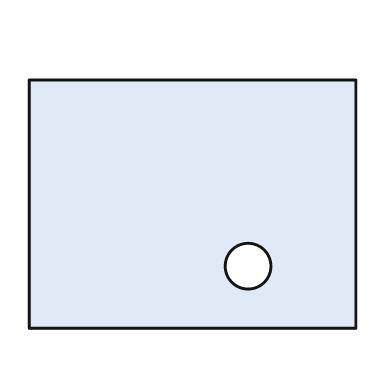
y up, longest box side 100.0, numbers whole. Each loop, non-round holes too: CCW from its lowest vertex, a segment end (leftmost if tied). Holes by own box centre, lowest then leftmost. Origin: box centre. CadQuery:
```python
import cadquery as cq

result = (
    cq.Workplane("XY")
    .moveTo(-50.0, -38.0)
    .lineTo(50.0, -38.0)
    .lineTo(50.0, 38.0)
    .lineTo(-50.0, 38.0)
    .close()
    .moveTo(17.0, -19.0)
    .circle(7.0)
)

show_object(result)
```